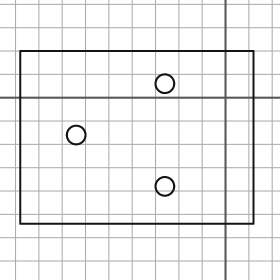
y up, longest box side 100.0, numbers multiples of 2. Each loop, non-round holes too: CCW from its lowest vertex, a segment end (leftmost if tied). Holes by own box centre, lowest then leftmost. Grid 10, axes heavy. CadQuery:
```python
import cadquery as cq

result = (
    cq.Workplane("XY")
    .moveTo(-88.0, -54.0)
    .lineTo(12.0, -54.0)
    .lineTo(12.0, 20.0)
    .lineTo(-88.0, 20.0)
    .close()
    .moveTo(-26.0, -38.0)
    .circle(4.0)
    .moveTo(-64.0, -16.0)
    .circle(4.0)
    .moveTo(-26.0, 6.0)
    .circle(4.0)
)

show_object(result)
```